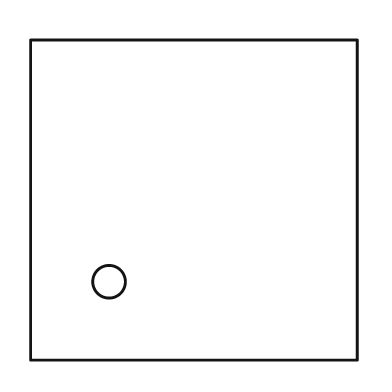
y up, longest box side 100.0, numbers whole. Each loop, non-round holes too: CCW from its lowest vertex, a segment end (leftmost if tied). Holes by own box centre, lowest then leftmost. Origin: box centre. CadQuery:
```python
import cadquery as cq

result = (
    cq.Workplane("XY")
    .moveTo(-50.0, -49.0)
    .lineTo(50.0, -49.0)
    .lineTo(50.0, 49.0)
    .lineTo(-50.0, 49.0)
    .close()
    .moveTo(-26.0, -25.0)
    .circle(5.0)
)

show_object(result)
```